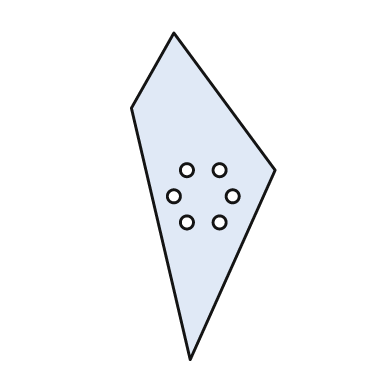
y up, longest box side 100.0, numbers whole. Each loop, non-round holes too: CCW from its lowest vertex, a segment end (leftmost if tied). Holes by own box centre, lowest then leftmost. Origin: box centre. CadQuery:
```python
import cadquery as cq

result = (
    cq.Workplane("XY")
    .moveTo(-4.0, -50.0)
    .lineTo(22.0, 8.0)
    .lineTo(-9.0, 50.0)
    .lineTo(-22.0, 27.0)
    .close()
    .moveTo(-5.0, -8.0)
    .circle(2.0)
    .moveTo(5.0, -8.0)
    .circle(2.0)
    .moveTo(-9.0, 0.0)
    .circle(2.0)
    .moveTo(9.0, 0.0)
    .circle(2.0)
    .moveTo(-5.0, 8.0)
    .circle(2.0)
    .moveTo(5.0, 8.0)
    .circle(2.0)
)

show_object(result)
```